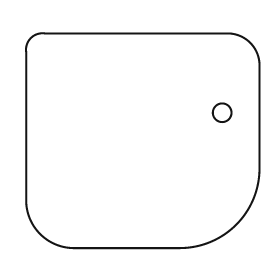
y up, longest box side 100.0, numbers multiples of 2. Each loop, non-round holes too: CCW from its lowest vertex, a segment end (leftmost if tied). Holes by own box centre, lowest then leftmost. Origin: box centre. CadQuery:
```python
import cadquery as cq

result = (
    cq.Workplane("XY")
    .moveTo(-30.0, -46.0)
    .lineTo(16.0, -46.0)
    .threePointArc((40.0, -36.0), (50.0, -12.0))
    .lineTo(50.0, 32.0)
    .threePointArc((46.0, 42.0), (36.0, 46.0))
    .lineTo(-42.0, 46.0)
    .threePointArc((-48.0, 44.0), (-50.0, 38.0))
    .lineTo(-50.0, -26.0)
    .threePointArc((-44.0, -40.0), (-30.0, -46.0))
    .close()
    .moveTo(34.0, 12.0)
    .circle(4.0)
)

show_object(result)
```